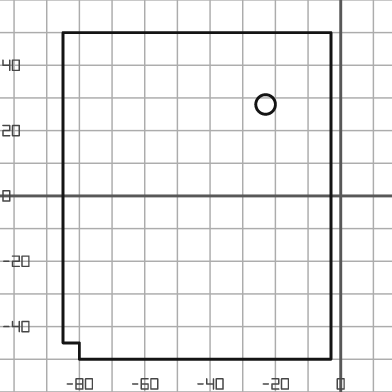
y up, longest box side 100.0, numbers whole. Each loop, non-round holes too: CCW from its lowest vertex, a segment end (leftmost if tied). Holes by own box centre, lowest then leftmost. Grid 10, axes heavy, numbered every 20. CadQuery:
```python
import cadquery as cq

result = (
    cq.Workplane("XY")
    .moveTo(-80.0, -50.0)
    .lineTo(-3.0, -50.0)
    .lineTo(-3.0, 50.0)
    .lineTo(-85.0, 50.0)
    .lineTo(-85.0, -45.0)
    .lineTo(-80.0, -45.0)
    .close()
    .moveTo(-23.0, 28.0)
    .circle(3.0)
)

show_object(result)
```